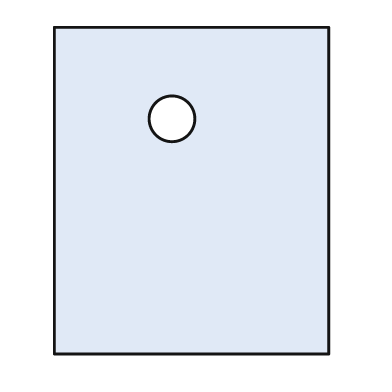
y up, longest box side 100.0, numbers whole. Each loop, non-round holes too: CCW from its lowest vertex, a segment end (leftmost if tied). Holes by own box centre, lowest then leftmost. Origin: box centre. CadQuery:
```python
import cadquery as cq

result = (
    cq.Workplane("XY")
    .moveTo(-42.0, -50.0)
    .lineTo(42.0, -50.0)
    .lineTo(42.0, 50.0)
    .lineTo(-42.0, 50.0)
    .close()
    .moveTo(-6.0, 22.0)
    .circle(7.0)
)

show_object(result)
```